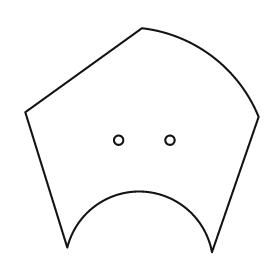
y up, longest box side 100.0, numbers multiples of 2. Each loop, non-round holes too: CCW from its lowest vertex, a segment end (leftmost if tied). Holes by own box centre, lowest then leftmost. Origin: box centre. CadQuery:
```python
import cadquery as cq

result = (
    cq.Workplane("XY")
    .moveTo(30.0, -48.0)
    .lineTo(50.0, 10.0)
    .threePointArc((30.0, 36.0), (0.0, 48.0))
    .lineTo(-50.0, 12.0)
    .lineTo(-32.0, -46.0)
    .threePointArc((0.0, -22.0), (30.0, -48.0))
    .close()
    .moveTo(-10.0, 0.0)
    .circle(2.0)
    .moveTo(12.0, 0.0)
    .circle(2.0)
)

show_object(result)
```